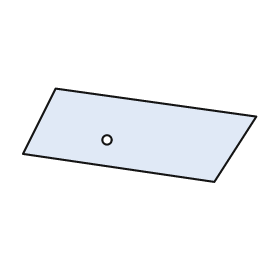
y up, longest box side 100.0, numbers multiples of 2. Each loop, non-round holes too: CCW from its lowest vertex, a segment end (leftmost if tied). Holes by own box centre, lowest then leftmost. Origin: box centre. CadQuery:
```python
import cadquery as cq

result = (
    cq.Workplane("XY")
    .moveTo(32.0, -20.0)
    .lineTo(50.0, 8.0)
    .lineTo(-36.0, 20.0)
    .lineTo(-50.0, -8.0)
    .close()
    .moveTo(-14.0, -2.0)
    .circle(2.0)
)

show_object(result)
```